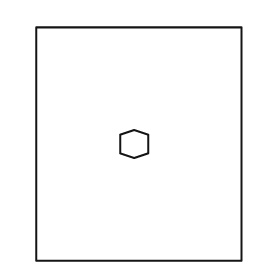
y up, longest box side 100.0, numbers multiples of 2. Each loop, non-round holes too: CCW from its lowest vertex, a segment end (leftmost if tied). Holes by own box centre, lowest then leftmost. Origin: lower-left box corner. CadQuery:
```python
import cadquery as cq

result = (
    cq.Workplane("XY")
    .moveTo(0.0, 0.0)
    .lineTo(88.0, 0.0)
    .lineTo(88.0, 100.0)
    .lineTo(0.0, 100.0)
    .close()
    .moveTo(42.0, 44.0)
    .lineTo(48.0, 46.0)
    .lineTo(48.0, 54.0)
    .lineTo(42.0, 56.0)
    .lineTo(36.0, 54.0)
    .lineTo(36.0, 46.0)
    .close()
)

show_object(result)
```